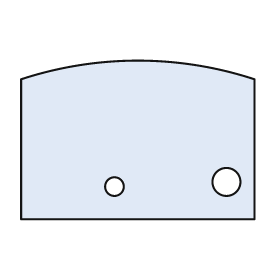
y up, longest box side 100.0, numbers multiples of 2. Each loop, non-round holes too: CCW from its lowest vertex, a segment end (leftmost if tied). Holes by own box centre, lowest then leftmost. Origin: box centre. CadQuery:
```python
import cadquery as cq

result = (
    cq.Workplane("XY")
    .moveTo(-50.0, -34.0)
    .lineTo(50.0, -34.0)
    .lineTo(50.0, 26.0)
    .threePointArc((0.0, 34.0), (-50.0, 26.0))
    .close()
    .moveTo(-10.0, -20.0)
    .circle(4.0)
    .moveTo(38.0, -18.0)
    .circle(6.0)
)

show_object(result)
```